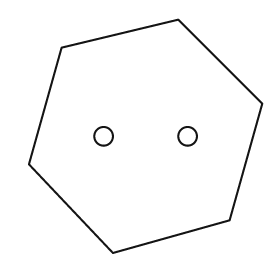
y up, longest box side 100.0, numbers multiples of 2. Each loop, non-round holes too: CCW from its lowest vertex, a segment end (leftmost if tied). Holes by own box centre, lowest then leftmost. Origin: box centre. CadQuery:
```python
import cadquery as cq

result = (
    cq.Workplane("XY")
    .moveTo(-14.0, -50.0)
    .lineTo(36.0, -36.0)
    .lineTo(50.0, 14.0)
    .lineTo(14.0, 50.0)
    .lineTo(-36.0, 38.0)
    .lineTo(-50.0, -12.0)
    .close()
    .moveTo(-18.0, 0.0)
    .circle(4.0)
    .moveTo(18.0, 0.0)
    .circle(4.0)
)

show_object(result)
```